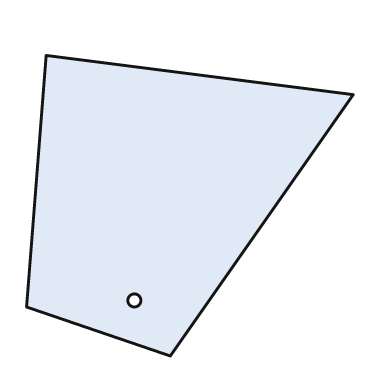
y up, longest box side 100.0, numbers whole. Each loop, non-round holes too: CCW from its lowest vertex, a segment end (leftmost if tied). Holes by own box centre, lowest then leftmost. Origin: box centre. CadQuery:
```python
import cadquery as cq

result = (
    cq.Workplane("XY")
    .moveTo(-6.0, -46.0)
    .lineTo(50.0, 34.0)
    .lineTo(-44.0, 46.0)
    .lineTo(-50.0, -31.0)
    .close()
    .moveTo(-17.0, -29.0)
    .circle(2.0)
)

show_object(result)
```